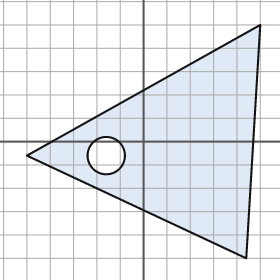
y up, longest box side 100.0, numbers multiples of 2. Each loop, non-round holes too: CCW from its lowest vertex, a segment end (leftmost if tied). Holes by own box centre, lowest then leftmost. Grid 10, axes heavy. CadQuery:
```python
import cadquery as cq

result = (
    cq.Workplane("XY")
    .moveTo(44.0, -50.0)
    .lineTo(50.0, 50.0)
    .lineTo(-50.0, -6.0)
    .close()
    .moveTo(-16.0, -6.0)
    .circle(8.0)
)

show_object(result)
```